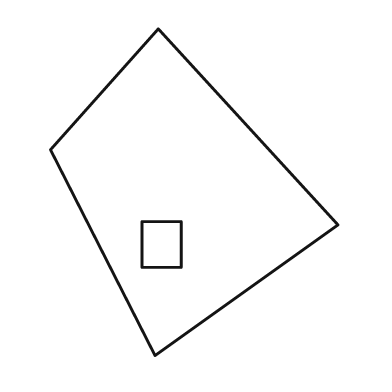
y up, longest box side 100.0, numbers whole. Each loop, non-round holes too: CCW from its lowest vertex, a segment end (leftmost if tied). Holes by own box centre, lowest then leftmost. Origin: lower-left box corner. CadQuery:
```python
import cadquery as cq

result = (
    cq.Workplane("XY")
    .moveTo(32.0, 0.0)
    .lineTo(88.0, 40.0)
    .lineTo(33.0, 100.0)
    .lineTo(0.0, 63.0)
    .close()
    .moveTo(28.0, 27.0)
    .lineTo(40.0, 27.0)
    .lineTo(40.0, 41.0)
    .lineTo(28.0, 41.0)
    .close()
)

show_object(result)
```